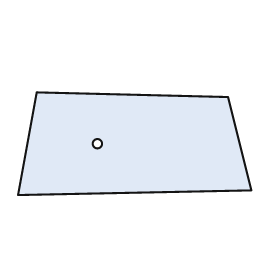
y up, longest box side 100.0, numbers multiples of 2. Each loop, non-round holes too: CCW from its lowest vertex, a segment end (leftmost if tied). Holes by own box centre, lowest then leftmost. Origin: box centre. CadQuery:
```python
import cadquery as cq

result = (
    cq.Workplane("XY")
    .moveTo(-50.0, -22.0)
    .lineTo(50.0, -20.0)
    .lineTo(40.0, 20.0)
    .lineTo(-42.0, 22.0)
    .close()
    .moveTo(-16.0, 0.0)
    .circle(2.0)
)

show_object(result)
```